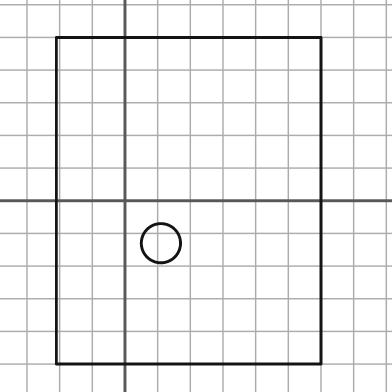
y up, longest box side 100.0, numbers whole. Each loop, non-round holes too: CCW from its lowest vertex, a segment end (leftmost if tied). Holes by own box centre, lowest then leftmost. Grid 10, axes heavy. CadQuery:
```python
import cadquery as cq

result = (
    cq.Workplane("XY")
    .moveTo(-21.0, -50.0)
    .lineTo(60.0, -50.0)
    .lineTo(60.0, 50.0)
    .lineTo(-21.0, 50.0)
    .close()
    .moveTo(11.0, -13.0)
    .circle(6.0)
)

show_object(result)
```